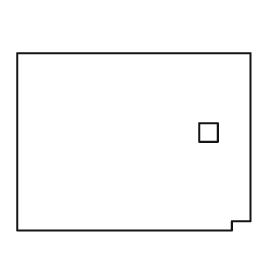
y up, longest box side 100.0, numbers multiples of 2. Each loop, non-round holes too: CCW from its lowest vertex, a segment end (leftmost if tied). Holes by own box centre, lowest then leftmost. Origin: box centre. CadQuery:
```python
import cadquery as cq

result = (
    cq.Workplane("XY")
    .moveTo(-50.0, -38.0)
    .lineTo(42.0, -38.0)
    .lineTo(42.0, -34.0)
    .lineTo(50.0, -34.0)
    .lineTo(50.0, 38.0)
    .lineTo(-50.0, 38.0)
    .close()
    .moveTo(28.0, 0.0)
    .lineTo(36.0, 0.0)
    .lineTo(36.0, 8.0)
    .lineTo(28.0, 8.0)
    .close()
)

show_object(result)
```